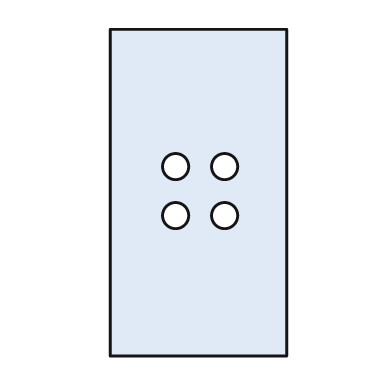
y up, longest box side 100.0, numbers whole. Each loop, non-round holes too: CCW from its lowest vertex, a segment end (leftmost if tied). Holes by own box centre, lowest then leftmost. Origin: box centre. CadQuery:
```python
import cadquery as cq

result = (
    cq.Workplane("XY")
    .moveTo(-27.0, -50.0)
    .lineTo(27.0, -50.0)
    .lineTo(27.0, 50.0)
    .lineTo(-27.0, 50.0)
    .close()
    .moveTo(-7.0, -7.0)
    .circle(4.0)
    .moveTo(8.0, -7.0)
    .circle(4.0)
    .moveTo(-7.0, 8.0)
    .circle(4.0)
    .moveTo(8.0, 8.0)
    .circle(4.0)
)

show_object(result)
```